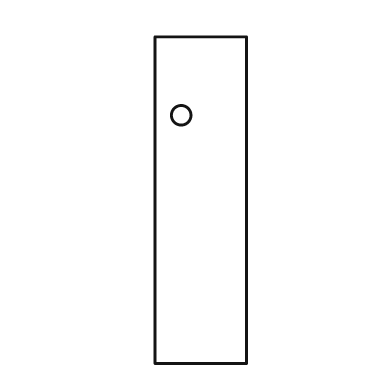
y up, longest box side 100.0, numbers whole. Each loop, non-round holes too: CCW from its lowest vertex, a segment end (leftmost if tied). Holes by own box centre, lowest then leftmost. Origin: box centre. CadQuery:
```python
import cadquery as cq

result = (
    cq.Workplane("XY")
    .moveTo(-14.0, -50.0)
    .lineTo(14.0, -50.0)
    .lineTo(14.0, 50.0)
    .lineTo(-14.0, 50.0)
    .close()
    .moveTo(-6.0, 26.0)
    .circle(3.0)
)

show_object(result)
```